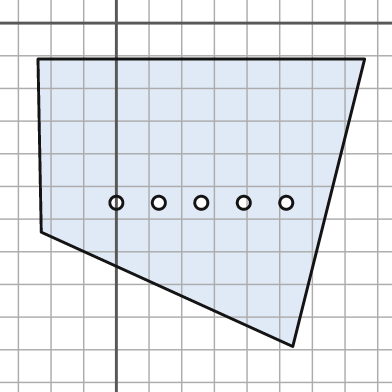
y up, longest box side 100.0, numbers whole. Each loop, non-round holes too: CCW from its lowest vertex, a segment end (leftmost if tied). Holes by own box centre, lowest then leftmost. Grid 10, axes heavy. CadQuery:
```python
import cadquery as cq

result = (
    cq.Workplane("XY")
    .moveTo(54.0, -99.0)
    .lineTo(76.0, -11.0)
    .lineTo(-24.0, -11.0)
    .lineTo(-23.0, -64.0)
    .close()
    .moveTo(0.0, -55.0)
    .circle(2.0)
    .moveTo(13.0, -55.0)
    .circle(2.0)
    .moveTo(26.0, -55.0)
    .circle(2.0)
    .moveTo(39.0, -55.0)
    .circle(2.0)
    .moveTo(52.0, -55.0)
    .circle(2.0)
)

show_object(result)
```